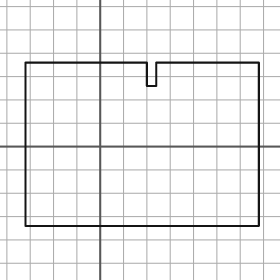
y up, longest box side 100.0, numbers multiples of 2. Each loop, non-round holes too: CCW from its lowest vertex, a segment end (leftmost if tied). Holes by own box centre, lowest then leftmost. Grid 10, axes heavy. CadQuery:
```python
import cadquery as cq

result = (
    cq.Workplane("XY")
    .moveTo(-32.0, -34.0)
    .lineTo(68.0, -34.0)
    .lineTo(68.0, 36.0)
    .lineTo(24.0, 36.0)
    .lineTo(24.0, 26.0)
    .lineTo(20.0, 26.0)
    .lineTo(20.0, 36.0)
    .lineTo(-32.0, 36.0)
    .close()
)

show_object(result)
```